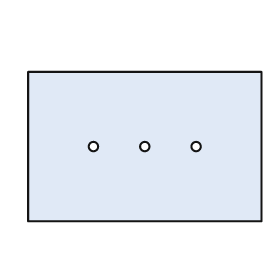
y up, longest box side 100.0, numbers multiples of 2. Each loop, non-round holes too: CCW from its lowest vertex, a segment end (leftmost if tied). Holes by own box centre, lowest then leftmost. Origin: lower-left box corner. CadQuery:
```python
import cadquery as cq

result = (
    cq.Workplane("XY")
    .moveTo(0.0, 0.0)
    .lineTo(100.0, 0.0)
    .lineTo(100.0, 64.0)
    .lineTo(0.0, 64.0)
    .close()
    .moveTo(28.0, 32.0)
    .circle(2.0)
    .moveTo(50.0, 32.0)
    .circle(2.0)
    .moveTo(72.0, 32.0)
    .circle(2.0)
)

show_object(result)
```